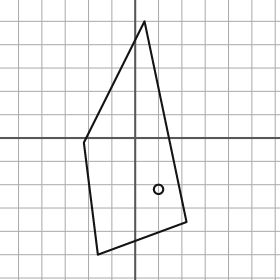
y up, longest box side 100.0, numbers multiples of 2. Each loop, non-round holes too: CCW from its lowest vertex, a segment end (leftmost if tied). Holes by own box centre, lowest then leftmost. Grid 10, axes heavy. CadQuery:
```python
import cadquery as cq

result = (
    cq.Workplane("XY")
    .moveTo(-16.0, -50.0)
    .lineTo(22.0, -36.0)
    .lineTo(4.0, 50.0)
    .lineTo(-22.0, -2.0)
    .close()
    .moveTo(10.0, -22.0)
    .circle(2.0)
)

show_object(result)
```